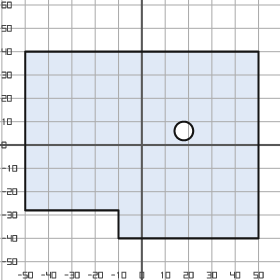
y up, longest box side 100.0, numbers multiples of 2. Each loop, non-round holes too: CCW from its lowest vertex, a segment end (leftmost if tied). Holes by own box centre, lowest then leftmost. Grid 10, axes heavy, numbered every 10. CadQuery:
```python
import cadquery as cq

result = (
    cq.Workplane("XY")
    .moveTo(-10.0, -40.0)
    .lineTo(50.0, -40.0)
    .lineTo(50.0, 40.0)
    .lineTo(-50.0, 40.0)
    .lineTo(-50.0, -28.0)
    .lineTo(-10.0, -28.0)
    .close()
    .moveTo(18.0, 6.0)
    .circle(4.0)
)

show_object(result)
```